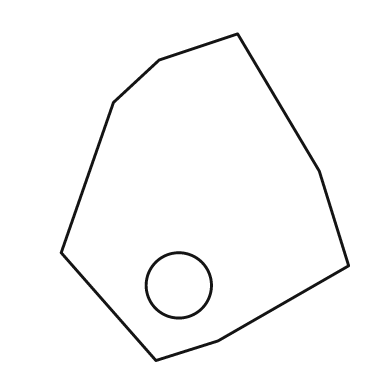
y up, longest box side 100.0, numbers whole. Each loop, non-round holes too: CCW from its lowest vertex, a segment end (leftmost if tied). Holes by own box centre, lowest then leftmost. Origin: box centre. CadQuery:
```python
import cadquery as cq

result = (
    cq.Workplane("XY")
    .moveTo(-15.0, -50.0)
    .lineTo(4.0, -44.0)
    .lineTo(44.0, -21.0)
    .lineTo(35.0, 8.0)
    .lineTo(10.0, 50.0)
    .lineTo(-14.0, 42.0)
    .lineTo(-28.0, 29.0)
    .lineTo(-44.0, -17.0)
    .close()
    .moveTo(-8.0, -27.0)
    .circle(10.0)
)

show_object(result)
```